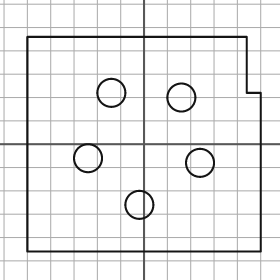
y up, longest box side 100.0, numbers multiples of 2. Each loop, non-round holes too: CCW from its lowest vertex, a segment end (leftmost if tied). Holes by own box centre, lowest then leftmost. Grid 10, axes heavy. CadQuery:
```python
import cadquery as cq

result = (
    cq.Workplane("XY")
    .moveTo(-50.0, -46.0)
    .lineTo(50.0, -46.0)
    .lineTo(50.0, 22.0)
    .lineTo(44.0, 22.0)
    .lineTo(44.0, 46.0)
    .lineTo(-50.0, 46.0)
    .close()
    .moveTo(-2.0, -26.0)
    .circle(6.0)
    .moveTo(24.0, -8.0)
    .circle(6.0)
    .moveTo(-24.0, -6.0)
    .circle(6.0)
    .moveTo(16.0, 20.0)
    .circle(6.0)
    .moveTo(-14.0, 22.0)
    .circle(6.0)
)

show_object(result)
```